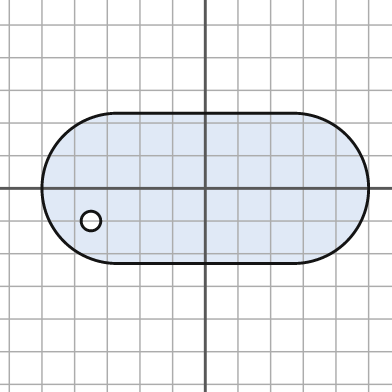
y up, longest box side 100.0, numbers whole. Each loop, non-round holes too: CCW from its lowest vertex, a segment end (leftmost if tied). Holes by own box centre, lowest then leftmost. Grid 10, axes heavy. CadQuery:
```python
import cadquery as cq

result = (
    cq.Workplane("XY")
    .moveTo(-27.0, -23.0)
    .lineTo(27.0, -23.0)
    .threePointArc((50.0, 0.0), (27.0, 23.0))
    .lineTo(-27.0, 23.0)
    .threePointArc((-50.0, 0.0), (-27.0, -23.0))
    .close()
    .moveTo(-35.0, -10.0)
    .circle(3.0)
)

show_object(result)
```